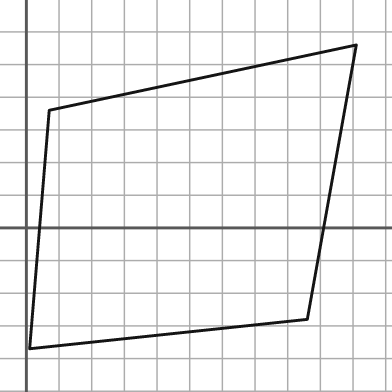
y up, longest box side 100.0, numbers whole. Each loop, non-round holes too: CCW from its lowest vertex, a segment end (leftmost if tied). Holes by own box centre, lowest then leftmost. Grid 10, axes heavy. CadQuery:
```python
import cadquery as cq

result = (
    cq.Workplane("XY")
    .moveTo(1.0, -37.0)
    .lineTo(86.0, -28.0)
    .lineTo(101.0, 56.0)
    .lineTo(7.0, 36.0)
    .close()
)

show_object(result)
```